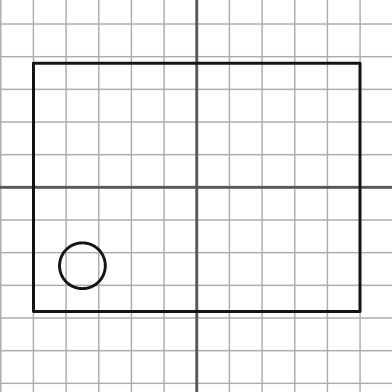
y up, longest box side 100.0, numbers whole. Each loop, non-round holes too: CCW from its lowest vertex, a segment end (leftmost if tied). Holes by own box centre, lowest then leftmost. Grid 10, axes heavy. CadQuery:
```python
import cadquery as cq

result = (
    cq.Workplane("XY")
    .moveTo(-50.0, -38.0)
    .lineTo(50.0, -38.0)
    .lineTo(50.0, 38.0)
    .lineTo(-50.0, 38.0)
    .close()
    .moveTo(-35.0, -24.0)
    .circle(7.0)
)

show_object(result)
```